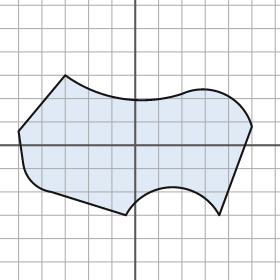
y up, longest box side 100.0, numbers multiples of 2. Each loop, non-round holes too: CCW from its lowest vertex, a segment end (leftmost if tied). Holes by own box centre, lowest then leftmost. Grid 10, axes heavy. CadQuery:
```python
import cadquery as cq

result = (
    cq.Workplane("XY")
    .moveTo(-4.0, -30.0)
    .threePointArc((16.0, -18.0), (36.0, -30.0))
    .lineTo(50.0, 8.0)
    .threePointArc((38.0, 22.0), (20.0, 22.0))
    .threePointArc((-6.0, 20.0), (-30.0, 30.0))
    .lineTo(-50.0, 6.0)
    .lineTo(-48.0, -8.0)
    .threePointArc((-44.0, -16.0), (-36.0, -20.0))
    .close()
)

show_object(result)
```